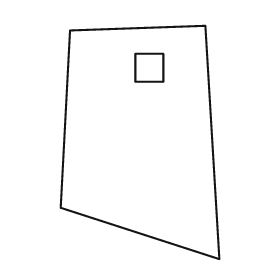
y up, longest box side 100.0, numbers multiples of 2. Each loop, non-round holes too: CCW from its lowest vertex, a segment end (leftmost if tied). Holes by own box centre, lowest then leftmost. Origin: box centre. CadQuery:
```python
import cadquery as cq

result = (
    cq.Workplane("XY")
    .moveTo(34.0, -50.0)
    .lineTo(28.0, 50.0)
    .lineTo(-30.0, 48.0)
    .lineTo(-34.0, -28.0)
    .close()
    .moveTo(-2.0, 26.0)
    .lineTo(10.0, 26.0)
    .lineTo(10.0, 38.0)
    .lineTo(-2.0, 38.0)
    .close()
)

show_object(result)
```